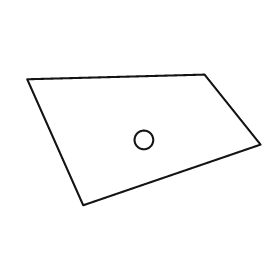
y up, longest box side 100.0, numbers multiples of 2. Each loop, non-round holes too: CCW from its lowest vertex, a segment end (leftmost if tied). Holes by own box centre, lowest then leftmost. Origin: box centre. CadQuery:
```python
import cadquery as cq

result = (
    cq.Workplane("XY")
    .moveTo(-26.0, -28.0)
    .lineTo(50.0, -2.0)
    .lineTo(26.0, 28.0)
    .lineTo(-50.0, 26.0)
    .close()
    .moveTo(0.0, 0.0)
    .circle(4.0)
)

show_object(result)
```